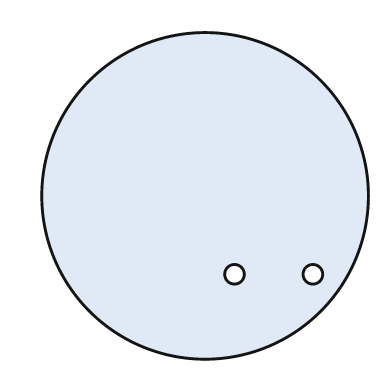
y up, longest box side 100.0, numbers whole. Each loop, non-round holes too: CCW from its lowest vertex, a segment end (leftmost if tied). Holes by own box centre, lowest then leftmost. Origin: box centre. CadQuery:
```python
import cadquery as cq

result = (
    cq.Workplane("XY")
    .moveTo(0.0, 0.0)
    .circle(50.0)
    .moveTo(9.0, -24.0)
    .circle(3.0)
    .moveTo(33.0, -24.0)
    .circle(3.0)
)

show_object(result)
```